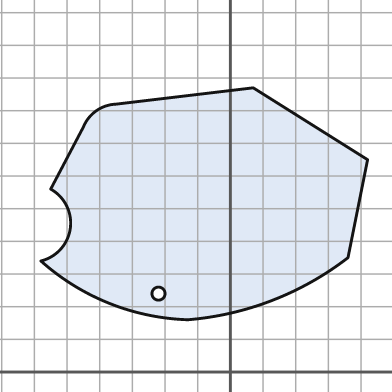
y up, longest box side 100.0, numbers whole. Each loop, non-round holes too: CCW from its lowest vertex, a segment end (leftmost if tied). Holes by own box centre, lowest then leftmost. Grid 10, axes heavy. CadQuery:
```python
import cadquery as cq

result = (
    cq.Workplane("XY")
    .moveTo(-13.0, 16.0)
    .threePointArc((13.0, 22.0), (36.0, 35.0))
    .lineTo(42.0, 65.0)
    .lineTo(7.0, 87.0)
    .lineTo(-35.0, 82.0)
    .threePointArc((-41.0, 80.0), (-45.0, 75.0))
    .lineTo(-55.0, 56.0)
    .threePointArc((-49.0, 44.0), (-58.0, 34.0))
    .threePointArc((-37.0, 21.0), (-13.0, 16.0))
    .close()
    .moveTo(-22.0, 24.0)
    .circle(2.0)
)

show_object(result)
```